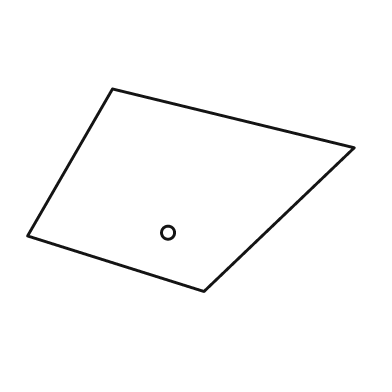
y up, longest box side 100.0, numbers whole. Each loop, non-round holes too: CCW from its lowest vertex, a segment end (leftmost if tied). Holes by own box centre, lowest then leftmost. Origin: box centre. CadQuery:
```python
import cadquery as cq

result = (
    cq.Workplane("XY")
    .moveTo(4.0, -31.0)
    .lineTo(50.0, 13.0)
    .lineTo(-24.0, 31.0)
    .lineTo(-50.0, -14.0)
    .close()
    .moveTo(-7.0, -13.0)
    .circle(2.0)
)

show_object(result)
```